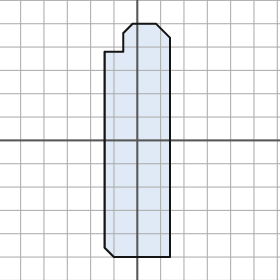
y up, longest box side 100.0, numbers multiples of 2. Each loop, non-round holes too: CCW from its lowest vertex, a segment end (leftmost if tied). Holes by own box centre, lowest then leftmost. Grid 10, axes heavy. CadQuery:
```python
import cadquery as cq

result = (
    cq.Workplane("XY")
    .moveTo(-10.0, -50.0)
    .lineTo(14.0, -50.0)
    .lineTo(14.0, 44.0)
    .lineTo(8.0, 50.0)
    .lineTo(-2.0, 50.0)
    .lineTo(-6.0, 46.0)
    .lineTo(-6.0, 38.0)
    .lineTo(-14.0, 38.0)
    .lineTo(-14.0, -46.0)
    .close()
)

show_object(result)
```